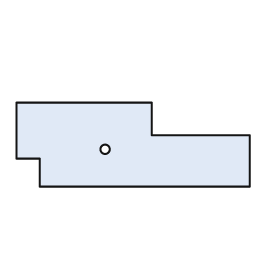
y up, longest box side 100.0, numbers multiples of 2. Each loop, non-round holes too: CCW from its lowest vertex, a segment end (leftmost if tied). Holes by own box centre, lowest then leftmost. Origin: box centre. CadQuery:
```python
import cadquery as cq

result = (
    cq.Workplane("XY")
    .moveTo(-40.0, -18.0)
    .lineTo(50.0, -18.0)
    .lineTo(50.0, 4.0)
    .lineTo(8.0, 4.0)
    .lineTo(8.0, 18.0)
    .lineTo(-50.0, 18.0)
    .lineTo(-50.0, -6.0)
    .lineTo(-40.0, -6.0)
    .close()
    .moveTo(-12.0, -2.0)
    .circle(2.0)
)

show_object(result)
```